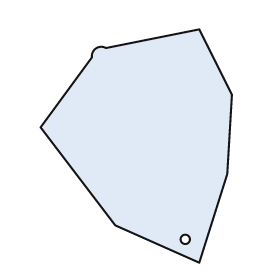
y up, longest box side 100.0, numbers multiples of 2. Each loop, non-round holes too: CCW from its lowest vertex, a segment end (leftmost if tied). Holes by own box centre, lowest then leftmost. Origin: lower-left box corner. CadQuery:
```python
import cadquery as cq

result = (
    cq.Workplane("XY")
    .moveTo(68.0, 0.0)
    .lineTo(80.0, 38.0)
    .lineTo(82.0, 72.0)
    .lineTo(68.0, 100.0)
    .lineTo(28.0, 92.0)
    .threePointArc((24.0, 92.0), (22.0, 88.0))
    .lineTo(0.0, 58.0)
    .lineTo(32.0, 16.0)
    .close()
    .moveTo(62.0, 10.0)
    .circle(2.0)
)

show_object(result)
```